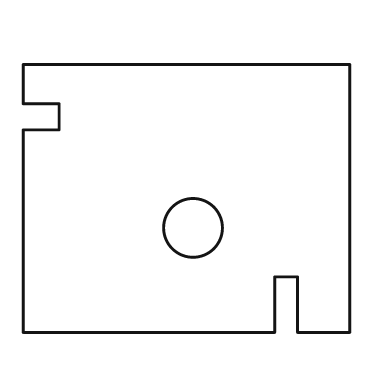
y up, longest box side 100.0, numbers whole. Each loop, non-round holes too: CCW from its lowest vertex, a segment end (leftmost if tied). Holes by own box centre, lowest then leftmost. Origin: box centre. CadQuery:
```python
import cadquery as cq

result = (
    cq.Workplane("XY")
    .moveTo(-50.0, -41.0)
    .lineTo(27.0, -41.0)
    .lineTo(27.0, -24.0)
    .lineTo(34.0, -24.0)
    .lineTo(34.0, -41.0)
    .lineTo(50.0, -41.0)
    .lineTo(50.0, 41.0)
    .lineTo(-50.0, 41.0)
    .lineTo(-50.0, 29.0)
    .lineTo(-39.0, 29.0)
    .lineTo(-39.0, 21.0)
    .lineTo(-50.0, 21.0)
    .close()
    .moveTo(2.0, -9.0)
    .circle(9.0)
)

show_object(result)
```